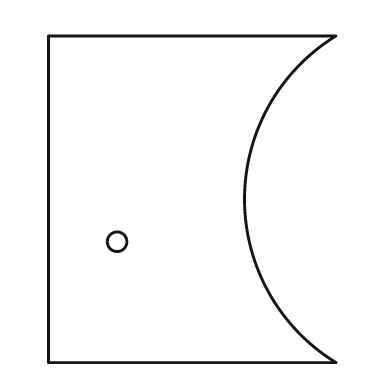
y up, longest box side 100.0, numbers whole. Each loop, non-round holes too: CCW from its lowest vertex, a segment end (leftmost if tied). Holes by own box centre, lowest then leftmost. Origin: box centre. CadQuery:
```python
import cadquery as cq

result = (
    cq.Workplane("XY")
    .moveTo(-44.0, -50.0)
    .lineTo(44.0, -50.0)
    .threePointArc((16.0, 0.0), (44.0, 50.0))
    .lineTo(-44.0, 50.0)
    .close()
    .moveTo(-23.0, -13.0)
    .circle(3.0)
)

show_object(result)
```